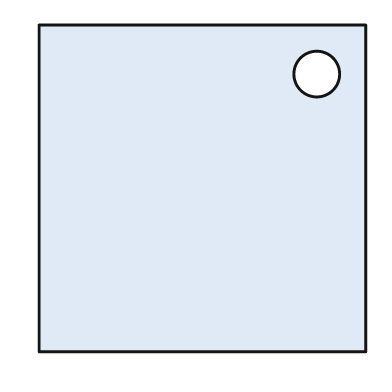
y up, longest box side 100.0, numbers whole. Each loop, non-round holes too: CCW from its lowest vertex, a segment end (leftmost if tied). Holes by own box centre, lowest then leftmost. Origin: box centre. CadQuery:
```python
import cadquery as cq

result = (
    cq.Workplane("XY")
    .moveTo(-50.0, -50.0)
    .lineTo(50.0, -50.0)
    .lineTo(50.0, 50.0)
    .lineTo(-50.0, 50.0)
    .close()
    .moveTo(35.0, 35.0)
    .circle(7.0)
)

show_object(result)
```